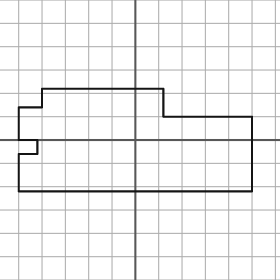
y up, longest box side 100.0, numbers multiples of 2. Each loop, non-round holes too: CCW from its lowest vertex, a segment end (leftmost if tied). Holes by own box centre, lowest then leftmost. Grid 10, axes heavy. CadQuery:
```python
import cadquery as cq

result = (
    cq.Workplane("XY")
    .moveTo(-50.0, -22.0)
    .lineTo(50.0, -22.0)
    .lineTo(50.0, 10.0)
    .lineTo(12.0, 10.0)
    .lineTo(12.0, 22.0)
    .lineTo(-40.0, 22.0)
    .lineTo(-40.0, 14.0)
    .lineTo(-50.0, 14.0)
    .lineTo(-50.0, 0.0)
    .lineTo(-42.0, 0.0)
    .lineTo(-42.0, -6.0)
    .lineTo(-50.0, -6.0)
    .close()
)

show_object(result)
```